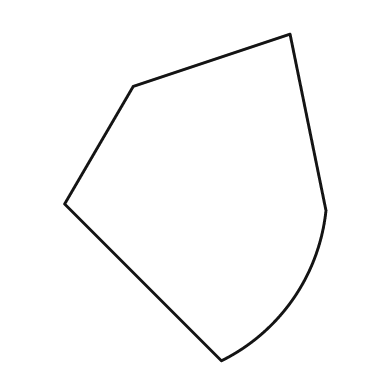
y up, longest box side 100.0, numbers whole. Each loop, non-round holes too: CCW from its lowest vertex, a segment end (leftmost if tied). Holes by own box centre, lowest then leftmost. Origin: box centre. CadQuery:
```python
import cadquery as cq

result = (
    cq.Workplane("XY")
    .moveTo(8.0, -50.0)
    .threePointArc((30.0, -31.0), (40.0, -4.0))
    .lineTo(29.0, 50.0)
    .lineTo(-19.0, 34.0)
    .lineTo(-40.0, -2.0)
    .close()
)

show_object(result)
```